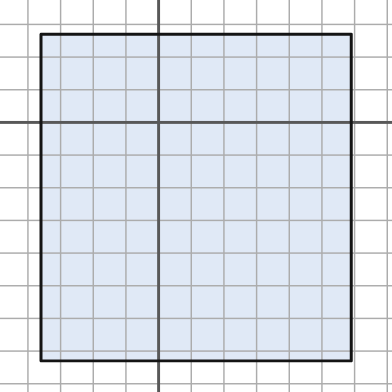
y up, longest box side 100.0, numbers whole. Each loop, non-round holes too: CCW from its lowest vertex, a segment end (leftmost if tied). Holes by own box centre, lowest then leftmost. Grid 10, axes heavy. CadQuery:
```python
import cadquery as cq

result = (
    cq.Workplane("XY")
    .moveTo(-36.0, -73.0)
    .lineTo(59.0, -73.0)
    .lineTo(59.0, 27.0)
    .lineTo(-36.0, 27.0)
    .close()
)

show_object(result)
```